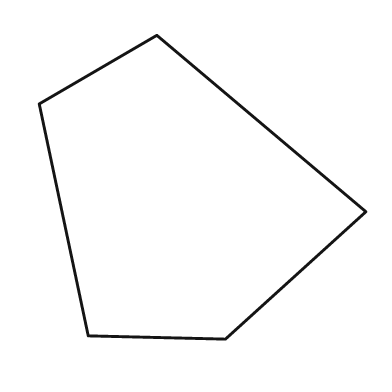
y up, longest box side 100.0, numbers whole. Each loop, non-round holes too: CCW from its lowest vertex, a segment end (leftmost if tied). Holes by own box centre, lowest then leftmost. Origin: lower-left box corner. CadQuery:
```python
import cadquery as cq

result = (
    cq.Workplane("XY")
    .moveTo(57.0, 0.0)
    .lineTo(100.0, 39.0)
    .lineTo(36.0, 93.0)
    .lineTo(0.0, 72.0)
    .lineTo(15.0, 1.0)
    .close()
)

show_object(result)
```